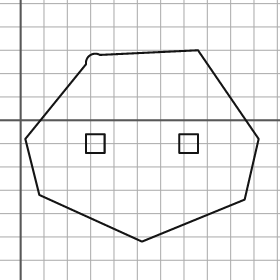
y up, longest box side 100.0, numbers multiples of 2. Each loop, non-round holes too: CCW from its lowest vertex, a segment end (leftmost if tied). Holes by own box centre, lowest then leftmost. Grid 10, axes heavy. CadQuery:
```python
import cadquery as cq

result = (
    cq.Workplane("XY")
    .moveTo(52.0, -52.0)
    .lineTo(96.0, -34.0)
    .lineTo(102.0, -8.0)
    .lineTo(76.0, 30.0)
    .lineTo(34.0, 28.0)
    .threePointArc((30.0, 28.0), (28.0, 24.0))
    .lineTo(2.0, -8.0)
    .lineTo(8.0, -32.0)
    .close()
    .moveTo(28.0, -14.0)
    .lineTo(36.0, -14.0)
    .lineTo(36.0, -6.0)
    .lineTo(28.0, -6.0)
    .close()
    .moveTo(68.0, -14.0)
    .lineTo(76.0, -14.0)
    .lineTo(76.0, -6.0)
    .lineTo(68.0, -6.0)
    .close()
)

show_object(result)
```